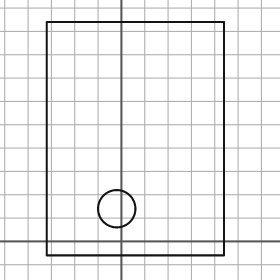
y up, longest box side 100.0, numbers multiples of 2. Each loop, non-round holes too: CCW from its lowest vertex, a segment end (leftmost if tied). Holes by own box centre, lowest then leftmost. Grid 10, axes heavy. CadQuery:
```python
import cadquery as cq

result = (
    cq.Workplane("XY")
    .moveTo(-32.0, -6.0)
    .lineTo(44.0, -6.0)
    .lineTo(44.0, 94.0)
    .lineTo(-32.0, 94.0)
    .close()
    .moveTo(-2.0, 14.0)
    .circle(8.0)
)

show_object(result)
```